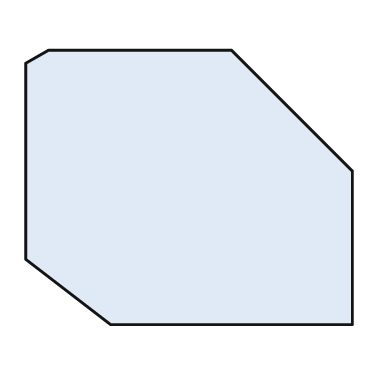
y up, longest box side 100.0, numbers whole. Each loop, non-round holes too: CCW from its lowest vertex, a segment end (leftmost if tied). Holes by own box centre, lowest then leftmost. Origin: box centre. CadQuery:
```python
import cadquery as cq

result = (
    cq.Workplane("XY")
    .moveTo(-24.0, -42.0)
    .lineTo(50.0, -42.0)
    .lineTo(50.0, 5.0)
    .lineTo(13.0, 42.0)
    .lineTo(-43.0, 42.0)
    .lineTo(-50.0, 38.0)
    .lineTo(-50.0, -22.0)
    .close()
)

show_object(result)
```